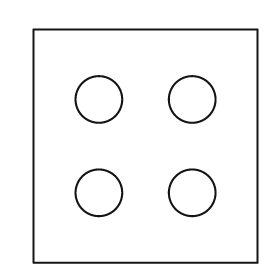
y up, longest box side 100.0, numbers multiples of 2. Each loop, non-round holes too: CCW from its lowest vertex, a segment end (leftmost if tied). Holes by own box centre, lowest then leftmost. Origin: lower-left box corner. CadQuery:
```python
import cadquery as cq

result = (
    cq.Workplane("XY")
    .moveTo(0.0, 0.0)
    .lineTo(96.0, 0.0)
    .lineTo(96.0, 100.0)
    .lineTo(0.0, 100.0)
    .close()
    .moveTo(28.0, 30.0)
    .circle(10.0)
    .moveTo(68.0, 30.0)
    .circle(10.0)
    .moveTo(28.0, 70.0)
    .circle(10.0)
    .moveTo(68.0, 70.0)
    .circle(10.0)
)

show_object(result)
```